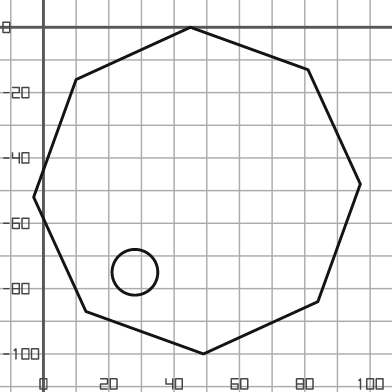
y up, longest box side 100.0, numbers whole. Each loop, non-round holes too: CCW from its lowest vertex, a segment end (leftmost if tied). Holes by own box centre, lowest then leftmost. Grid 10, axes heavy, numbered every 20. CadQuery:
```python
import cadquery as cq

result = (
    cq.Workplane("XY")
    .moveTo(49.0, -100.0)
    .lineTo(84.0, -84.0)
    .lineTo(97.0, -48.0)
    .lineTo(81.0, -13.0)
    .lineTo(45.0, 0.0)
    .lineTo(10.0, -16.0)
    .lineTo(-3.0, -52.0)
    .lineTo(13.0, -87.0)
    .close()
    .moveTo(28.0, -75.0)
    .circle(7.0)
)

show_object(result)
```